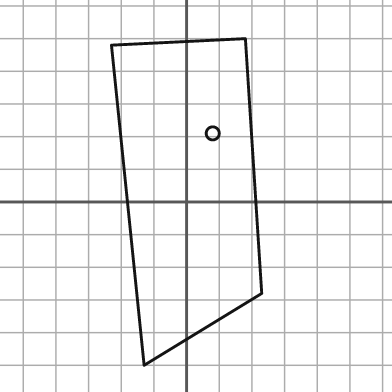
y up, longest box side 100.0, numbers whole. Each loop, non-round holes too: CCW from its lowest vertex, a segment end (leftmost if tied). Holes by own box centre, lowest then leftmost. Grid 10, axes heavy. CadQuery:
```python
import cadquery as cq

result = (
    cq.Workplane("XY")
    .moveTo(-13.0, -50.0)
    .lineTo(23.0, -28.0)
    .lineTo(18.0, 50.0)
    .lineTo(-23.0, 48.0)
    .close()
    .moveTo(8.0, 21.0)
    .circle(2.0)
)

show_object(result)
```